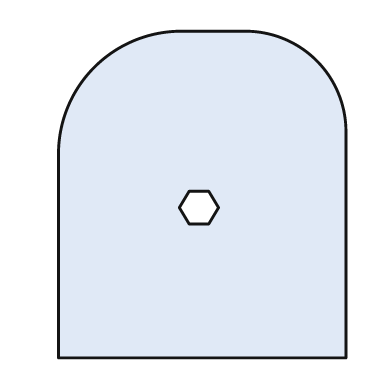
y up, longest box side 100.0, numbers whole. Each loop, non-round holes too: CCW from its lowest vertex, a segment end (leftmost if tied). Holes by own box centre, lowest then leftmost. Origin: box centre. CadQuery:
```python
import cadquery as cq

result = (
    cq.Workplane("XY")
    .moveTo(-44.0, -50.0)
    .lineTo(44.0, -50.0)
    .lineTo(44.0, 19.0)
    .threePointArc((35.0, 41.0), (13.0, 50.0))
    .lineTo(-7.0, 50.0)
    .threePointArc((-33.0, 39.0), (-44.0, 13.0))
    .close()
    .moveTo(-4.0, -9.0)
    .lineTo(2.0, -9.0)
    .lineTo(5.0, -4.0)
    .lineTo(2.0, 1.0)
    .lineTo(-4.0, 1.0)
    .lineTo(-7.0, -4.0)
    .close()
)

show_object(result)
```